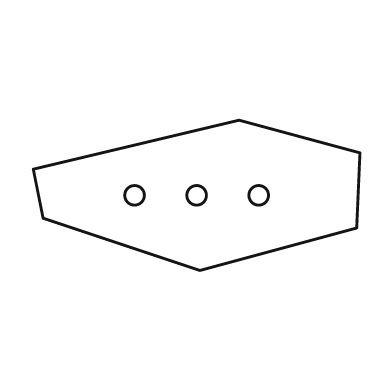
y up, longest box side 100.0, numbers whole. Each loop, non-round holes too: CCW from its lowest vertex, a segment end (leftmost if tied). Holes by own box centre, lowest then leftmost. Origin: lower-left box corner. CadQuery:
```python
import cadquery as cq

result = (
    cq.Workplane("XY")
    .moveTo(51.0, 0.0)
    .lineTo(99.0, 13.0)
    .lineTo(100.0, 36.0)
    .lineTo(63.0, 46.0)
    .lineTo(0.0, 31.0)
    .lineTo(3.0, 16.0)
    .close()
    .moveTo(31.0, 23.0)
    .circle(3.0)
    .moveTo(50.0, 23.0)
    .circle(3.0)
    .moveTo(69.0, 23.0)
    .circle(3.0)
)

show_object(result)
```